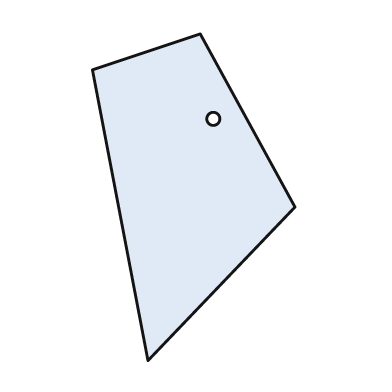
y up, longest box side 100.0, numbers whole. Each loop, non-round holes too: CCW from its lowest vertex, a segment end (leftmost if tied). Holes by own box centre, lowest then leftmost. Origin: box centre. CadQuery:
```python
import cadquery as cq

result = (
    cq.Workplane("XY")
    .moveTo(-14.0, -50.0)
    .lineTo(31.0, -3.0)
    .lineTo(2.0, 50.0)
    .lineTo(-31.0, 39.0)
    .close()
    .moveTo(6.0, 24.0)
    .circle(2.0)
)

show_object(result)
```